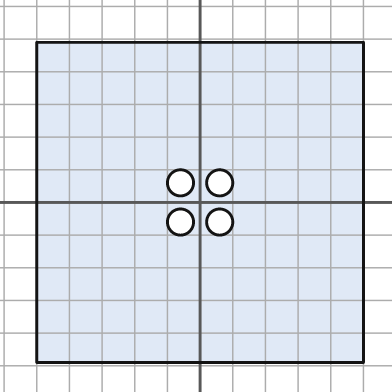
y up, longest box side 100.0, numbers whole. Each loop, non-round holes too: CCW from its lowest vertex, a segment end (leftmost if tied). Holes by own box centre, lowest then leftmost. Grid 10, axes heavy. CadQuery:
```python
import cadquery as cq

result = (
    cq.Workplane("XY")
    .moveTo(-50.0, -49.0)
    .lineTo(50.0, -49.0)
    .lineTo(50.0, 49.0)
    .lineTo(-50.0, 49.0)
    .close()
    .moveTo(-6.0, -6.0)
    .circle(4.0)
    .moveTo(6.0, -6.0)
    .circle(4.0)
    .moveTo(-6.0, 6.0)
    .circle(4.0)
    .moveTo(6.0, 6.0)
    .circle(4.0)
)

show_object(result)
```